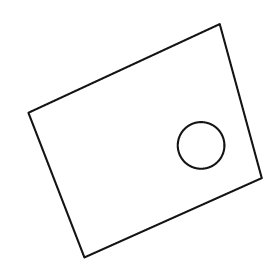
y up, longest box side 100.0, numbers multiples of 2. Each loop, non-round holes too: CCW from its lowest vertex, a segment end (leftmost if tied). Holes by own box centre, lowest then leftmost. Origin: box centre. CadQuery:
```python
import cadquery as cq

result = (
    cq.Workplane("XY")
    .moveTo(-26.0, -50.0)
    .lineTo(50.0, -16.0)
    .lineTo(32.0, 50.0)
    .lineTo(-50.0, 12.0)
    .close()
    .moveTo(24.0, -2.0)
    .circle(10.0)
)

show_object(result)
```